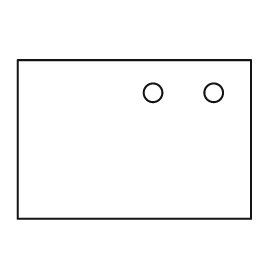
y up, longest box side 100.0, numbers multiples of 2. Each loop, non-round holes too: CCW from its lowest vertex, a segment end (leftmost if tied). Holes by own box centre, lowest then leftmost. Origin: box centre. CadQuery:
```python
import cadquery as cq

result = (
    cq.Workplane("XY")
    .moveTo(-50.0, -34.0)
    .lineTo(50.0, -34.0)
    .lineTo(50.0, 34.0)
    .lineTo(-50.0, 34.0)
    .close()
    .moveTo(8.0, 20.0)
    .circle(4.0)
    .moveTo(34.0, 20.0)
    .circle(4.0)
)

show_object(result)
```